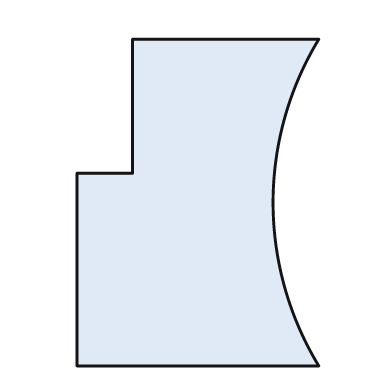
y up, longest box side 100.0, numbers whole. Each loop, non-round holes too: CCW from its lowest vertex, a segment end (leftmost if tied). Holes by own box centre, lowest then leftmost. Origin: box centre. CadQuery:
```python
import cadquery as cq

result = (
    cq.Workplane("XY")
    .moveTo(-37.0, -50.0)
    .lineTo(37.0, -50.0)
    .threePointArc((23.0, 0.0), (37.0, 50.0))
    .lineTo(-20.0, 50.0)
    .lineTo(-20.0, 9.0)
    .lineTo(-37.0, 9.0)
    .close()
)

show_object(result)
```